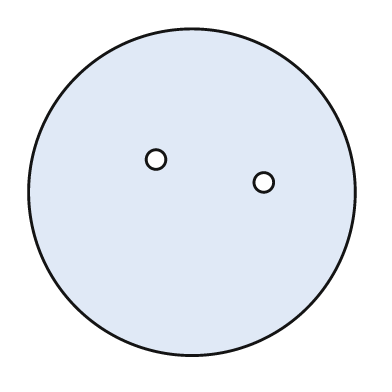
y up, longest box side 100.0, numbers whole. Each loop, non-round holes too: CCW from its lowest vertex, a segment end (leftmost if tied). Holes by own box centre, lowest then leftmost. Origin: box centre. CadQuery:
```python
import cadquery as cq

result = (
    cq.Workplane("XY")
    .moveTo(0.0, 0.0)
    .circle(50.0)
    .moveTo(22.0, 3.0)
    .circle(3.0)
    .moveTo(-11.0, 10.0)
    .circle(3.0)
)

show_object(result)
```